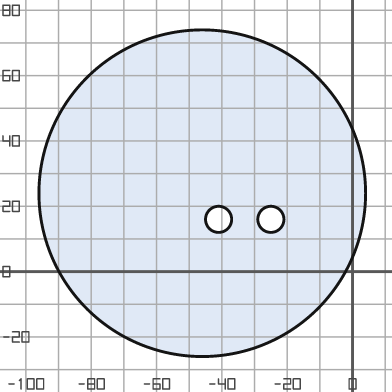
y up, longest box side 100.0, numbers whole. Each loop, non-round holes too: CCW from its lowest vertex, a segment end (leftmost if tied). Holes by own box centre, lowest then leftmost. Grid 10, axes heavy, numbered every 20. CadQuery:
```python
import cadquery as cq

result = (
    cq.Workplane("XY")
    .moveTo(-46.0, 24.0)
    .circle(50.0)
    .moveTo(-41.0, 16.0)
    .circle(4.0)
    .moveTo(-25.0, 16.0)
    .circle(4.0)
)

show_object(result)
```